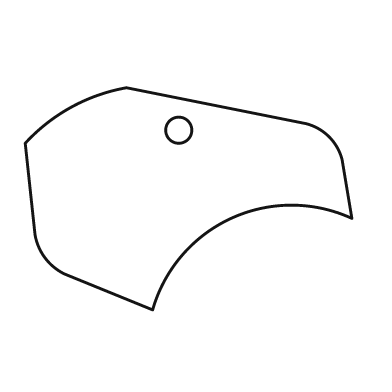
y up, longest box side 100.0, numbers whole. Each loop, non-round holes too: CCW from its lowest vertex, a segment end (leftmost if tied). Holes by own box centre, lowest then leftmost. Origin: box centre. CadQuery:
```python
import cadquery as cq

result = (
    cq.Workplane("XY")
    .moveTo(-11.0, -34.0)
    .threePointArc((13.0, -6.0), (50.0, -6.0))
    .lineTo(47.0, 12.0)
    .threePointArc((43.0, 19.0), (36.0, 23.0))
    .lineTo(-19.0, 34.0)
    .threePointArc((-36.0, 28.0), (-50.0, 17.0))
    .lineTo(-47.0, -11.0)
    .threePointArc((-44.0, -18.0), (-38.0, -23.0))
    .close()
    .moveTo(-3.0, 21.0)
    .circle(4.0)
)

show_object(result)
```